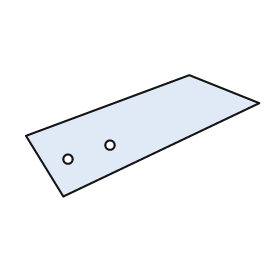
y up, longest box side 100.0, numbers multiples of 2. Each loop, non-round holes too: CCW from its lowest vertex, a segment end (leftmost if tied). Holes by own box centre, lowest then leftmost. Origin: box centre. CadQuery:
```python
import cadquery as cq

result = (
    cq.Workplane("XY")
    .moveTo(-34.0, -26.0)
    .lineTo(50.0, 14.0)
    .lineTo(20.0, 26.0)
    .lineTo(-50.0, 0.0)
    .close()
    .moveTo(-32.0, -10.0)
    .circle(2.0)
    .moveTo(-14.0, -4.0)
    .circle(2.0)
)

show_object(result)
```